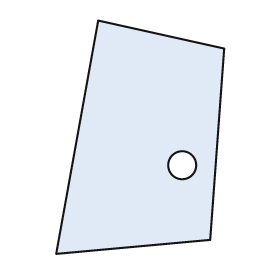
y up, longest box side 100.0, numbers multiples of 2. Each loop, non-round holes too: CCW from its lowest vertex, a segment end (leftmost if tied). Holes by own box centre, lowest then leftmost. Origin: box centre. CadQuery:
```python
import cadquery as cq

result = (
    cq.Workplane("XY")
    .moveTo(-36.0, -50.0)
    .lineTo(30.0, -44.0)
    .lineTo(36.0, 38.0)
    .lineTo(-18.0, 50.0)
    .close()
    .moveTo(18.0, -12.0)
    .circle(6.0)
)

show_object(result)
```